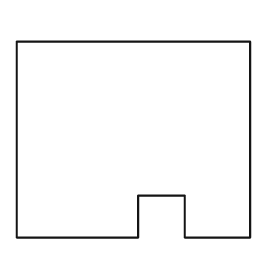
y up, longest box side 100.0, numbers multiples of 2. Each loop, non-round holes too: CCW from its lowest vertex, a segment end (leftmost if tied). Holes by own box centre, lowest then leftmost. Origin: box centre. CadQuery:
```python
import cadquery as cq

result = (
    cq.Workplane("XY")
    .moveTo(-50.0, -42.0)
    .lineTo(2.0, -42.0)
    .lineTo(2.0, -24.0)
    .lineTo(22.0, -24.0)
    .lineTo(22.0, -42.0)
    .lineTo(50.0, -42.0)
    .lineTo(50.0, 42.0)
    .lineTo(-50.0, 42.0)
    .close()
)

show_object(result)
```